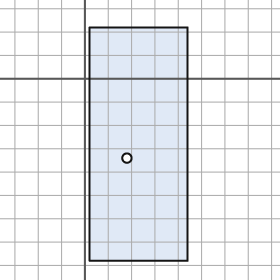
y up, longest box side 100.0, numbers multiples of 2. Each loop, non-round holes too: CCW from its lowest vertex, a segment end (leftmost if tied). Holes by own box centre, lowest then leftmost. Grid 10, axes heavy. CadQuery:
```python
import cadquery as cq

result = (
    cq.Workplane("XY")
    .moveTo(2.0, -78.0)
    .lineTo(44.0, -78.0)
    .lineTo(44.0, 22.0)
    .lineTo(2.0, 22.0)
    .close()
    .moveTo(18.0, -34.0)
    .circle(2.0)
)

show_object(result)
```